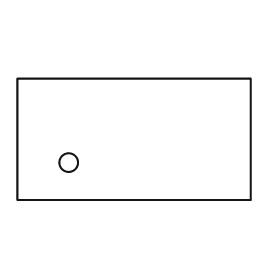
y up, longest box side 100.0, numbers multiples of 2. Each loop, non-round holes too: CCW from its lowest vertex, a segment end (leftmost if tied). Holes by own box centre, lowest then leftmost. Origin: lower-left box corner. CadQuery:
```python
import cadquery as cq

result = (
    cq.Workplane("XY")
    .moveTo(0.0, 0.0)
    .lineTo(100.0, 0.0)
    .lineTo(100.0, 52.0)
    .lineTo(0.0, 52.0)
    .close()
    .moveTo(22.0, 16.0)
    .circle(4.0)
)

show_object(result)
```